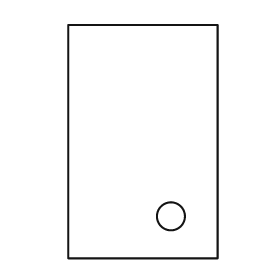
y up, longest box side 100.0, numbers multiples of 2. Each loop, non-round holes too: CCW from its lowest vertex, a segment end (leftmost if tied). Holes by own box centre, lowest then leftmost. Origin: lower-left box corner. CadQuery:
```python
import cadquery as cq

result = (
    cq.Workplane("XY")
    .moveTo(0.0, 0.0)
    .lineTo(64.0, 0.0)
    .lineTo(64.0, 100.0)
    .lineTo(0.0, 100.0)
    .close()
    .moveTo(44.0, 18.0)
    .circle(6.0)
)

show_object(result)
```